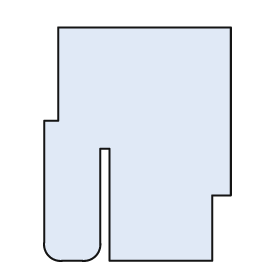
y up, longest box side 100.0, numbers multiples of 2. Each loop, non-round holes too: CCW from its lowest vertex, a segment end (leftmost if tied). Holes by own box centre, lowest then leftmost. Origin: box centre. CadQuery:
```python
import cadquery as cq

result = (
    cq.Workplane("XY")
    .moveTo(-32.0, -50.0)
    .lineTo(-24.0, -50.0)
    .threePointArc((-18.0, -48.0), (-16.0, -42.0))
    .lineTo(-16.0, -2.0)
    .lineTo(-12.0, -2.0)
    .lineTo(-12.0, -50.0)
    .lineTo(32.0, -50.0)
    .lineTo(32.0, -22.0)
    .lineTo(40.0, -22.0)
    .lineTo(40.0, 50.0)
    .lineTo(-34.0, 50.0)
    .lineTo(-34.0, 10.0)
    .lineTo(-40.0, 10.0)
    .lineTo(-40.0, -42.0)
    .threePointArc((-38.0, -48.0), (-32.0, -50.0))
    .close()
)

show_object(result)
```